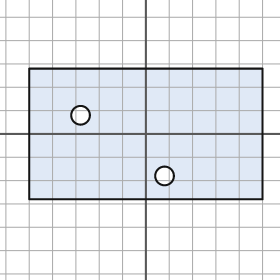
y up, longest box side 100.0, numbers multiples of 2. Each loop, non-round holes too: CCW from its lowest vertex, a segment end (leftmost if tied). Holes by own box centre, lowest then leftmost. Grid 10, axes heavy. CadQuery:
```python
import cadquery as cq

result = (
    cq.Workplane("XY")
    .moveTo(-50.0, -28.0)
    .lineTo(50.0, -28.0)
    .lineTo(50.0, 28.0)
    .lineTo(-50.0, 28.0)
    .close()
    .moveTo(8.0, -18.0)
    .circle(4.0)
    .moveTo(-28.0, 8.0)
    .circle(4.0)
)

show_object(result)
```